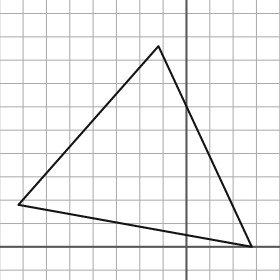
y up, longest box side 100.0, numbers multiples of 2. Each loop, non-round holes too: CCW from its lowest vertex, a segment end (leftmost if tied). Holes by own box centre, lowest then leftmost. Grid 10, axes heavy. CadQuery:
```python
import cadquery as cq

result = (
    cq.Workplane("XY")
    .moveTo(28.0, 0.0)
    .lineTo(-12.0, 86.0)
    .lineTo(-72.0, 18.0)
    .close()
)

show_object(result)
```